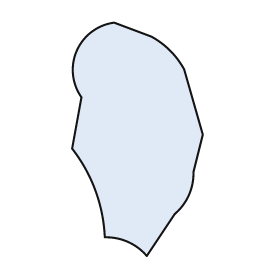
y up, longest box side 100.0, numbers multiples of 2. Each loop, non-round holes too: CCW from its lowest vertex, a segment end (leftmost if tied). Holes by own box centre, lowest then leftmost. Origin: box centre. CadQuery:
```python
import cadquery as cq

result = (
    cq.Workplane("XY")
    .moveTo(4.0, -50.0)
    .lineTo(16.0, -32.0)
    .threePointArc((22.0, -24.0), (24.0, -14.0))
    .lineTo(28.0, 2.0)
    .lineTo(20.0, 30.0)
    .threePointArc((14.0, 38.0), (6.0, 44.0))
    .lineTo(-10.0, 50.0)
    .threePointArc((-26.0, 38.0), (-24.0, 18.0))
    .lineTo(-28.0, -4.0)
    .threePointArc((-18.0, -22.0), (-14.0, -42.0))
    .threePointArc((-4.0, -44.0), (4.0, -50.0))
    .close()
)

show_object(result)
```